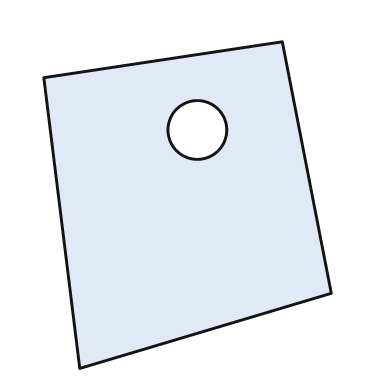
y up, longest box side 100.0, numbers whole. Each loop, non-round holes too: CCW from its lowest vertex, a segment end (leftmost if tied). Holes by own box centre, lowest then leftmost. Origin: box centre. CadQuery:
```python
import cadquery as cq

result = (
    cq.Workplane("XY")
    .moveTo(-33.0, -50.0)
    .lineTo(44.0, -27.0)
    .lineTo(29.0, 50.0)
    .lineTo(-44.0, 39.0)
    .close()
    .moveTo(3.0, 23.0)
    .circle(9.0)
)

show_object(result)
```